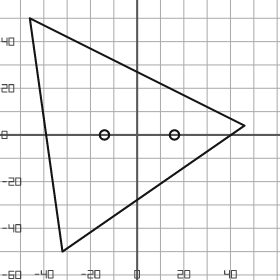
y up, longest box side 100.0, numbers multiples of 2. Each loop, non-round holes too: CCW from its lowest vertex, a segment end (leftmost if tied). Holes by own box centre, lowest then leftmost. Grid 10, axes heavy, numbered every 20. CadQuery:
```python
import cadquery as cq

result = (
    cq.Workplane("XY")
    .moveTo(-32.0, -50.0)
    .lineTo(46.0, 4.0)
    .lineTo(-46.0, 50.0)
    .close()
    .moveTo(-14.0, 0.0)
    .circle(2.0)
    .moveTo(16.0, 0.0)
    .circle(2.0)
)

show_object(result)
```